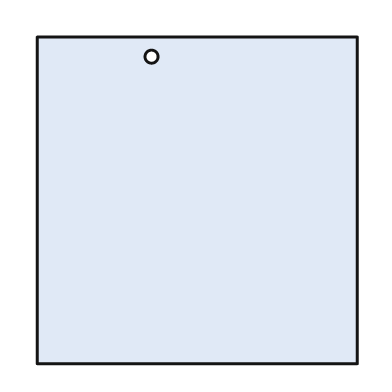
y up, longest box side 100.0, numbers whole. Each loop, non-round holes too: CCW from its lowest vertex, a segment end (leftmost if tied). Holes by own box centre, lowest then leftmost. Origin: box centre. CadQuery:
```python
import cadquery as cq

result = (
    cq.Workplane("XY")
    .moveTo(-49.0, -50.0)
    .lineTo(49.0, -50.0)
    .lineTo(49.0, 50.0)
    .lineTo(-49.0, 50.0)
    .close()
    .moveTo(-14.0, 44.0)
    .circle(2.0)
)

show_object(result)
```